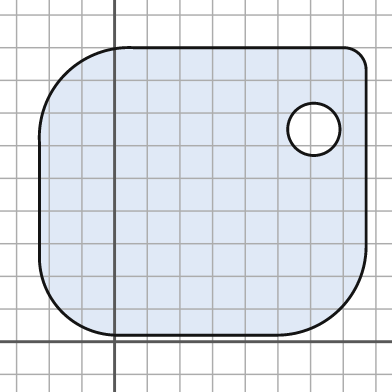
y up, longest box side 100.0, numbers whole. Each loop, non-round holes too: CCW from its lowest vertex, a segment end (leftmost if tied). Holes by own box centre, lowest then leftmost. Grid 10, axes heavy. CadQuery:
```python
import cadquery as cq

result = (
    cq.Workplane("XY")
    .moveTo(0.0, 2.0)
    .lineTo(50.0, 2.0)
    .threePointArc((69.0, 10.0), (77.0, 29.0))
    .lineTo(77.0, 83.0)
    .threePointArc((75.0, 88.0), (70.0, 90.0))
    .lineTo(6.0, 90.0)
    .threePointArc((-15.0, 82.0), (-23.0, 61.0))
    .lineTo(-23.0, 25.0)
    .threePointArc((-16.0, 9.0), (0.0, 2.0))
    .close()
    .moveTo(61.0, 65.0)
    .circle(8.0)
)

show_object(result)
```